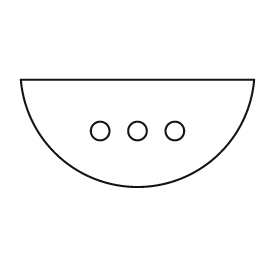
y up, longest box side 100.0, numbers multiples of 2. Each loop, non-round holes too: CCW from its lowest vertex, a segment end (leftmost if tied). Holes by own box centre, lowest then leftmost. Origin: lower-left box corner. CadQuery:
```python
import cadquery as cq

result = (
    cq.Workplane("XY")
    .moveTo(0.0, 46.0)
    .threePointArc((50.0, 0.0), (100.0, 46.0))
    .close()
    .moveTo(34.0, 24.0)
    .circle(4.0)
    .moveTo(50.0, 24.0)
    .circle(4.0)
    .moveTo(66.0, 24.0)
    .circle(4.0)
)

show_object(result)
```